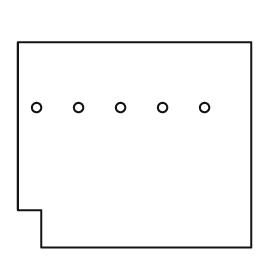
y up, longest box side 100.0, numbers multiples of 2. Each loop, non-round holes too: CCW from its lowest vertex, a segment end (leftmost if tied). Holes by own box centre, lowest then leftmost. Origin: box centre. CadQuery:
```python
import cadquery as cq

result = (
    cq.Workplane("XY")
    .moveTo(-40.0, -44.0)
    .lineTo(50.0, -44.0)
    .lineTo(50.0, 44.0)
    .lineTo(-50.0, 44.0)
    .lineTo(-50.0, -28.0)
    .lineTo(-40.0, -28.0)
    .close()
    .moveTo(-42.0, 16.0)
    .circle(2.0)
    .moveTo(-24.0, 16.0)
    .circle(2.0)
    .moveTo(-6.0, 16.0)
    .circle(2.0)
    .moveTo(12.0, 16.0)
    .circle(2.0)
    .moveTo(30.0, 16.0)
    .circle(2.0)
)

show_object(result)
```